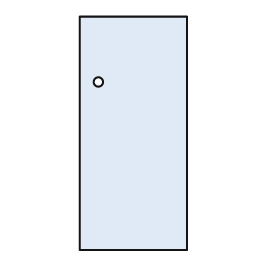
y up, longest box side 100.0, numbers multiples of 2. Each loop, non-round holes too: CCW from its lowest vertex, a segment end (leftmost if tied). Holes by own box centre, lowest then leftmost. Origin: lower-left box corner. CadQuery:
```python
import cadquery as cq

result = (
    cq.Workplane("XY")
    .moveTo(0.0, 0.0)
    .lineTo(46.0, 0.0)
    .lineTo(46.0, 100.0)
    .lineTo(0.0, 100.0)
    .close()
    .moveTo(8.0, 72.0)
    .circle(2.0)
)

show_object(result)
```